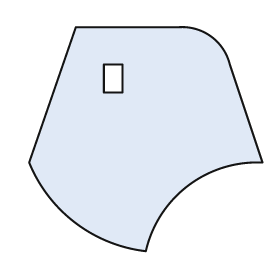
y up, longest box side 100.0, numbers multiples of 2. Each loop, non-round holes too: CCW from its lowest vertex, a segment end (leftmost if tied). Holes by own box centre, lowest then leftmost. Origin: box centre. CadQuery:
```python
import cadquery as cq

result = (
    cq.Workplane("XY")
    .moveTo(0.0, -48.0)
    .threePointArc((18.0, -20.0), (50.0, -10.0))
    .lineTo(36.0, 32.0)
    .threePointArc((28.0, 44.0), (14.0, 48.0))
    .lineTo(-30.0, 48.0)
    .lineTo(-50.0, -10.0)
    .threePointArc((-30.0, -36.0), (0.0, -48.0))
    .close()
    .moveTo(-18.0, 20.0)
    .lineTo(-10.0, 20.0)
    .lineTo(-10.0, 32.0)
    .lineTo(-18.0, 32.0)
    .close()
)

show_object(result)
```